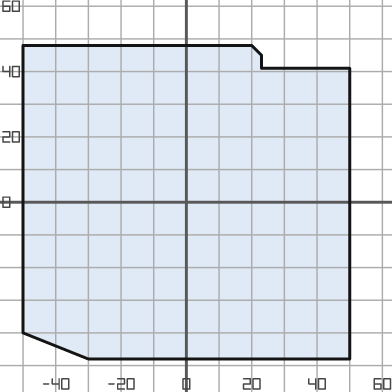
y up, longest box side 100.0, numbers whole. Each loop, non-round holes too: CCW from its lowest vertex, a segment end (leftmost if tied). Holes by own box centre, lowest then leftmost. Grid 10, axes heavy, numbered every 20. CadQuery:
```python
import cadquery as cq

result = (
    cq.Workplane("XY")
    .moveTo(-30.0, -48.0)
    .lineTo(50.0, -48.0)
    .lineTo(50.0, 41.0)
    .lineTo(23.0, 41.0)
    .lineTo(23.0, 45.0)
    .lineTo(20.0, 48.0)
    .lineTo(-50.0, 48.0)
    .lineTo(-50.0, -40.0)
    .close()
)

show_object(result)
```